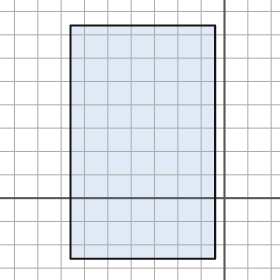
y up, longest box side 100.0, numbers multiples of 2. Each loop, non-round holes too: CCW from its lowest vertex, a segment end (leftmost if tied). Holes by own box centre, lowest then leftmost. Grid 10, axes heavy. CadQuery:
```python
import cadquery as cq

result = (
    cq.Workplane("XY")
    .moveTo(-66.0, -26.0)
    .lineTo(-4.0, -26.0)
    .lineTo(-4.0, 74.0)
    .lineTo(-66.0, 74.0)
    .close()
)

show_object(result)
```